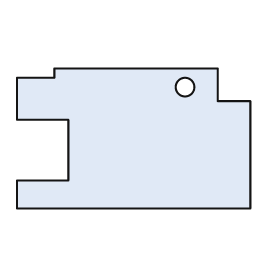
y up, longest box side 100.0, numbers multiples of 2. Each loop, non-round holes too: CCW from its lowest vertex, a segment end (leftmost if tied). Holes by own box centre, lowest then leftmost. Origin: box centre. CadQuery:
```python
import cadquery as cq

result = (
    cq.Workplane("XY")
    .moveTo(-50.0, -30.0)
    .lineTo(50.0, -30.0)
    .lineTo(50.0, 16.0)
    .lineTo(36.0, 16.0)
    .lineTo(36.0, 30.0)
    .lineTo(-34.0, 30.0)
    .lineTo(-34.0, 26.0)
    .lineTo(-50.0, 26.0)
    .lineTo(-50.0, 8.0)
    .lineTo(-28.0, 8.0)
    .lineTo(-28.0, -18.0)
    .lineTo(-50.0, -18.0)
    .close()
    .moveTo(22.0, 22.0)
    .circle(4.0)
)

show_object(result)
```